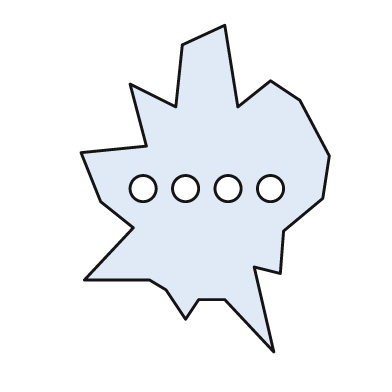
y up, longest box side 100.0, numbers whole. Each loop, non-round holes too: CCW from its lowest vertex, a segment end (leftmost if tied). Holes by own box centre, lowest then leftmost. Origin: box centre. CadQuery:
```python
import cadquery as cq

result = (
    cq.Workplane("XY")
    .moveTo(21.0, -50.0)
    .lineTo(15.0, -24.0)
    .lineTo(23.0, -26.0)
    .lineTo(24.0, -13.0)
    .lineTo(36.0, -3.0)
    .lineTo(38.0, 10.0)
    .lineTo(29.0, 27.0)
    .lineTo(20.0, 33.0)
    .lineTo(10.0, 25.0)
    .lineTo(6.0, 50.0)
    .lineTo(-7.0, 44.0)
    .lineTo(-9.0, 25.0)
    .lineTo(-23.0, 32.0)
    .lineTo(-18.0, 13.0)
    .lineTo(-38.0, 11.0)
    .lineTo(-32.0, -4.0)
    .lineTo(-22.0, -12.0)
    .lineTo(-37.0, -28.0)
    .lineTo(-17.0, -28.0)
    .lineTo(-12.0, -31.0)
    .lineTo(-6.0, -40.0)
    .lineTo(-2.0, -34.0)
    .lineTo(6.0, -34.0)
    .close()
    .moveTo(-19.0, 0.0)
    .circle(4.0)
    .moveTo(-6.0, 0.0)
    .circle(4.0)
    .moveTo(7.0, 0.0)
    .circle(4.0)
    .moveTo(20.0, 0.0)
    .circle(4.0)
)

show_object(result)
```